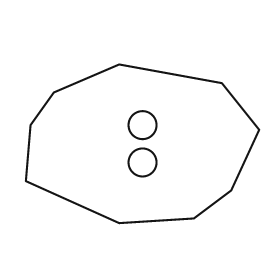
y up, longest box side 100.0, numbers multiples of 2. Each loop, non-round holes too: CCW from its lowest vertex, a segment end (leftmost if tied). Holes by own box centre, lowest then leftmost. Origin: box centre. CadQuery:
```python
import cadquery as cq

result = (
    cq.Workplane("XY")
    .moveTo(-10.0, -34.0)
    .lineTo(22.0, -32.0)
    .lineTo(38.0, -20.0)
    .lineTo(50.0, 6.0)
    .lineTo(34.0, 26.0)
    .lineTo(-10.0, 34.0)
    .lineTo(-38.0, 22.0)
    .lineTo(-48.0, 8.0)
    .lineTo(-50.0, -16.0)
    .close()
    .moveTo(0.0, -8.0)
    .circle(6.0)
    .moveTo(0.0, 8.0)
    .circle(6.0)
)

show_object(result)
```